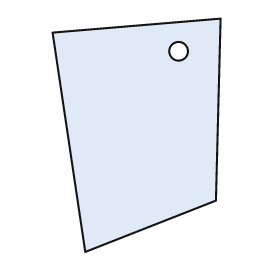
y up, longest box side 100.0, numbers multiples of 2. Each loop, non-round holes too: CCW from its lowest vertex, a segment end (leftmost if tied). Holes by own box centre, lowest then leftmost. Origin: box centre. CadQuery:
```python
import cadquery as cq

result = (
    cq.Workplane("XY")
    .moveTo(-22.0, -50.0)
    .lineTo(34.0, -28.0)
    .lineTo(36.0, 50.0)
    .lineTo(-36.0, 44.0)
    .close()
    .moveTo(18.0, 36.0)
    .circle(4.0)
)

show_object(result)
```